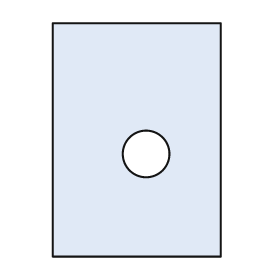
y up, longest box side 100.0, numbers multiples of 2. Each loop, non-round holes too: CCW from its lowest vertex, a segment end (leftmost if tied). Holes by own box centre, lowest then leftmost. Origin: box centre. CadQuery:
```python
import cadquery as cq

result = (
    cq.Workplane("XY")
    .moveTo(-36.0, -50.0)
    .lineTo(36.0, -50.0)
    .lineTo(36.0, 50.0)
    .lineTo(-36.0, 50.0)
    .close()
    .moveTo(4.0, -6.0)
    .circle(10.0)
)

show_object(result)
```